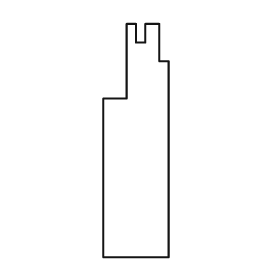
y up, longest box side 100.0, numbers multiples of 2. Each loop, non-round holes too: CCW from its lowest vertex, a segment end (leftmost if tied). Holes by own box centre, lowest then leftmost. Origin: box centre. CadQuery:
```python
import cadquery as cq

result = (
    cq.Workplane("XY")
    .moveTo(-14.0, -50.0)
    .lineTo(14.0, -50.0)
    .lineTo(14.0, 34.0)
    .lineTo(10.0, 34.0)
    .lineTo(10.0, 50.0)
    .lineTo(4.0, 50.0)
    .lineTo(4.0, 42.0)
    .lineTo(0.0, 42.0)
    .lineTo(0.0, 50.0)
    .lineTo(-4.0, 50.0)
    .lineTo(-4.0, 18.0)
    .lineTo(-14.0, 18.0)
    .close()
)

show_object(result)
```